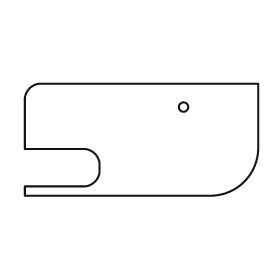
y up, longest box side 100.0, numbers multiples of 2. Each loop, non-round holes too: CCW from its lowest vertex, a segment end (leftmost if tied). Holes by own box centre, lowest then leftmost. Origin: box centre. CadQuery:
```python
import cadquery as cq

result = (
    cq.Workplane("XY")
    .moveTo(-50.0, -24.0)
    .lineTo(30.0, -24.0)
    .threePointArc((44.0, -18.0), (50.0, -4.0))
    .lineTo(50.0, 24.0)
    .lineTo(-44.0, 24.0)
    .threePointArc((-48.0, 22.0), (-50.0, 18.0))
    .lineTo(-50.0, -4.0)
    .lineTo(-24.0, -4.0)
    .threePointArc((-20.0, -6.0), (-18.0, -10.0))
    .lineTo(-18.0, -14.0)
    .threePointArc((-20.0, -18.0), (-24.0, -20.0))
    .lineTo(-50.0, -20.0)
    .close()
    .moveTo(18.0, 14.0)
    .circle(2.0)
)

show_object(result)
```